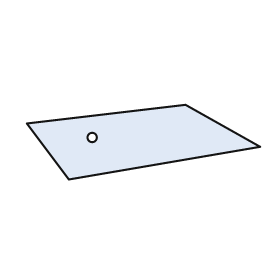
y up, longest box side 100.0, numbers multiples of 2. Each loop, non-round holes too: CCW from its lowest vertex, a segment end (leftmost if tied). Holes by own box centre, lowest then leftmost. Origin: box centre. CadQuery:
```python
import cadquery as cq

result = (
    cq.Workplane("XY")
    .moveTo(-32.0, -16.0)
    .lineTo(50.0, -2.0)
    .lineTo(18.0, 16.0)
    .lineTo(-50.0, 8.0)
    .close()
    .moveTo(-22.0, 2.0)
    .circle(2.0)
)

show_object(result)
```